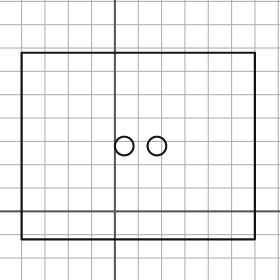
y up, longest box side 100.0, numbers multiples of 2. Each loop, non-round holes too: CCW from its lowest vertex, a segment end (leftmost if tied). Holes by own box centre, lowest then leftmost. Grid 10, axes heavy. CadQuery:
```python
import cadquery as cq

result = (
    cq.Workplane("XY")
    .moveTo(-40.0, -12.0)
    .lineTo(60.0, -12.0)
    .lineTo(60.0, 68.0)
    .lineTo(-40.0, 68.0)
    .close()
    .moveTo(4.0, 28.0)
    .circle(4.0)
    .moveTo(18.0, 28.0)
    .circle(4.0)
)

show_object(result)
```